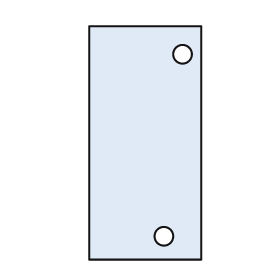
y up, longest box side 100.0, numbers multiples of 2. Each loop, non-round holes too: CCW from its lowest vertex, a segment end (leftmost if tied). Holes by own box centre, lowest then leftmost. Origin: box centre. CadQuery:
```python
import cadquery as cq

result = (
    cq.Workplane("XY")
    .moveTo(-24.0, -50.0)
    .lineTo(24.0, -50.0)
    .lineTo(24.0, 50.0)
    .lineTo(-24.0, 50.0)
    .close()
    .moveTo(8.0, -40.0)
    .circle(4.0)
    .moveTo(16.0, 38.0)
    .circle(4.0)
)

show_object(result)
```